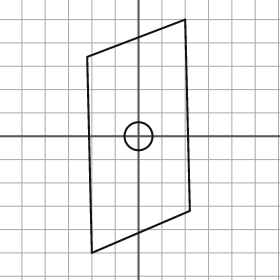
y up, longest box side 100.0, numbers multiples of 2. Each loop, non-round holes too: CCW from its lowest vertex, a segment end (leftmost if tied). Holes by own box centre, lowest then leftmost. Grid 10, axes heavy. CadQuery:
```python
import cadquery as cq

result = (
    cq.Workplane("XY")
    .moveTo(-20.0, -50.0)
    .lineTo(22.0, -32.0)
    .lineTo(20.0, 50.0)
    .lineTo(-22.0, 34.0)
    .close()
    .moveTo(0.0, 0.0)
    .circle(6.0)
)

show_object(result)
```